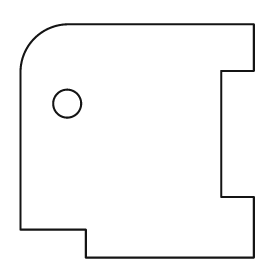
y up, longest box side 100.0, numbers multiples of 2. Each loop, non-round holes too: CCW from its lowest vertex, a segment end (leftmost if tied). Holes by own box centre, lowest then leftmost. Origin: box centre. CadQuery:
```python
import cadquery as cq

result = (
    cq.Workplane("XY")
    .moveTo(-22.0, -50.0)
    .lineTo(50.0, -50.0)
    .lineTo(50.0, -24.0)
    .lineTo(36.0, -24.0)
    .lineTo(36.0, 30.0)
    .lineTo(50.0, 30.0)
    .lineTo(50.0, 50.0)
    .lineTo(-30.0, 50.0)
    .threePointArc((-44.0, 44.0), (-50.0, 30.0))
    .lineTo(-50.0, -38.0)
    .lineTo(-22.0, -38.0)
    .close()
    .moveTo(-30.0, 16.0)
    .circle(6.0)
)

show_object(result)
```